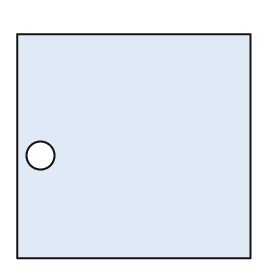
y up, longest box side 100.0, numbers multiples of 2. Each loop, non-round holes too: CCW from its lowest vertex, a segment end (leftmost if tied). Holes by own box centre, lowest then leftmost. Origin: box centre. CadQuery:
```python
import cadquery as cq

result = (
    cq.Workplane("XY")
    .moveTo(-50.0, -48.0)
    .lineTo(50.0, -48.0)
    .lineTo(50.0, 48.0)
    .lineTo(-50.0, 48.0)
    .close()
    .moveTo(-40.0, -4.0)
    .circle(6.0)
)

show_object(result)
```